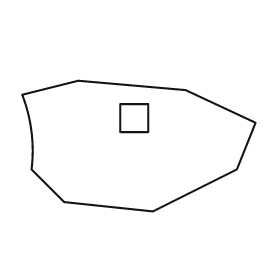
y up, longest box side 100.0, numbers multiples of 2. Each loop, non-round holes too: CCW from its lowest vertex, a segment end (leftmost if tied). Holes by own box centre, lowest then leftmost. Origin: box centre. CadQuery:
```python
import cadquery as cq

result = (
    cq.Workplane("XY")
    .moveTo(6.0, -28.0)
    .lineTo(42.0, -10.0)
    .lineTo(50.0, 10.0)
    .lineTo(20.0, 24.0)
    .lineTo(-26.0, 28.0)
    .lineTo(-50.0, 22.0)
    .threePointArc((-46.0, 6.0), (-46.0, -10.0))
    .lineTo(-32.0, -24.0)
    .close()
    .moveTo(-8.0, 6.0)
    .lineTo(4.0, 6.0)
    .lineTo(4.0, 18.0)
    .lineTo(-8.0, 18.0)
    .close()
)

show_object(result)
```